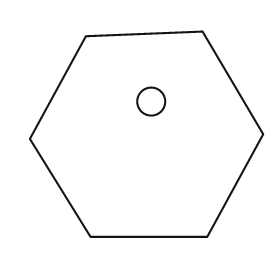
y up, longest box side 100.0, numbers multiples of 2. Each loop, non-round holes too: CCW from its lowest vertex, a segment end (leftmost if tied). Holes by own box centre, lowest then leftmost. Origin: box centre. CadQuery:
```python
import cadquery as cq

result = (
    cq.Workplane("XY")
    .moveTo(-24.0, -44.0)
    .lineTo(26.0, -44.0)
    .lineTo(50.0, 0.0)
    .lineTo(24.0, 44.0)
    .lineTo(-26.0, 42.0)
    .lineTo(-50.0, -2.0)
    .close()
    .moveTo(2.0, 14.0)
    .circle(6.0)
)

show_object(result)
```